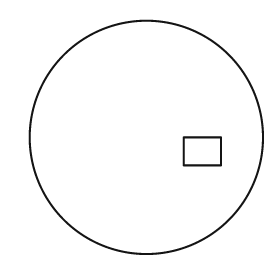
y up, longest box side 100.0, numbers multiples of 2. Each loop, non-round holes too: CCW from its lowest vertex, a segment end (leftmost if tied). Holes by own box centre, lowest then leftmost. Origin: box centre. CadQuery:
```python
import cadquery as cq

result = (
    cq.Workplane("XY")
    .moveTo(0.0, 0.0)
    .circle(50.0)
    .moveTo(16.0, -12.0)
    .lineTo(32.0, -12.0)
    .lineTo(32.0, 0.0)
    .lineTo(16.0, 0.0)
    .close()
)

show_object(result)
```